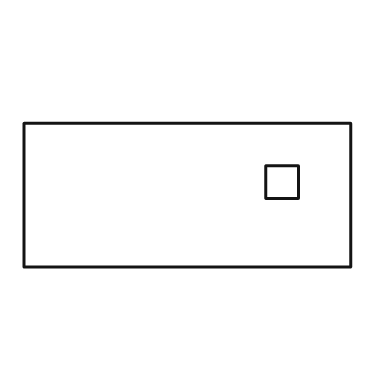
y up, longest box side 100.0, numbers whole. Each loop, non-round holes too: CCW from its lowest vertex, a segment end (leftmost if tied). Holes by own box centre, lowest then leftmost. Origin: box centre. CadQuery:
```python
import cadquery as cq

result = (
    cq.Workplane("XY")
    .moveTo(-50.0, -22.0)
    .lineTo(50.0, -22.0)
    .lineTo(50.0, 22.0)
    .lineTo(-50.0, 22.0)
    .close()
    .moveTo(24.0, -1.0)
    .lineTo(34.0, -1.0)
    .lineTo(34.0, 9.0)
    .lineTo(24.0, 9.0)
    .close()
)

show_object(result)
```